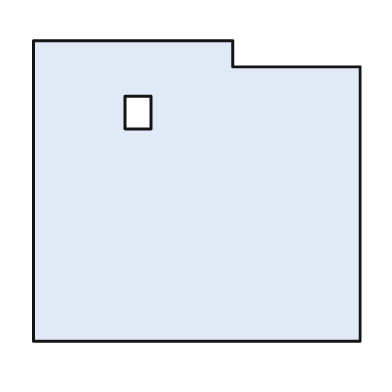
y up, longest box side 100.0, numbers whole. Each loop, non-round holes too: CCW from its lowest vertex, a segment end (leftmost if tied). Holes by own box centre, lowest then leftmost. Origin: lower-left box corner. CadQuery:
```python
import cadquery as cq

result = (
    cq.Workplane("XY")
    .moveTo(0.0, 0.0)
    .lineTo(100.0, 0.0)
    .lineTo(100.0, 84.0)
    .lineTo(61.0, 84.0)
    .lineTo(61.0, 92.0)
    .lineTo(0.0, 92.0)
    .close()
    .moveTo(28.0, 65.0)
    .lineTo(36.0, 65.0)
    .lineTo(36.0, 75.0)
    .lineTo(28.0, 75.0)
    .close()
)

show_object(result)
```